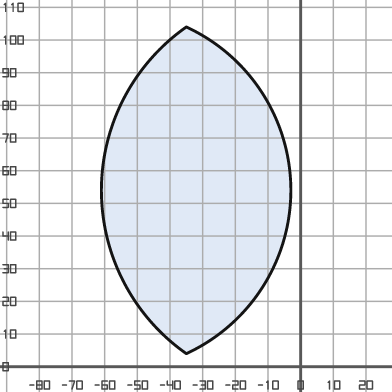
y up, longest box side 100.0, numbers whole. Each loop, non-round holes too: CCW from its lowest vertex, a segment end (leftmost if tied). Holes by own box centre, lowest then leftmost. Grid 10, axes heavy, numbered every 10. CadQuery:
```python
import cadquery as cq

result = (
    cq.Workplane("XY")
    .moveTo(-35.0, 4.0)
    .threePointArc((-3.0, 54.0), (-35.0, 104.0))
    .threePointArc((-61.0, 54.0), (-35.0, 4.0))
    .close()
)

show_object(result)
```